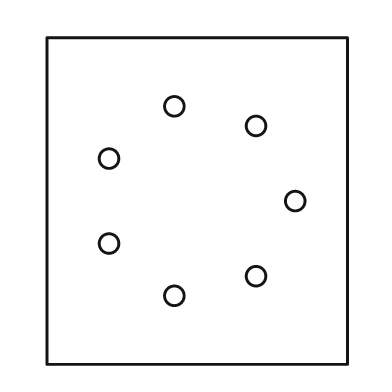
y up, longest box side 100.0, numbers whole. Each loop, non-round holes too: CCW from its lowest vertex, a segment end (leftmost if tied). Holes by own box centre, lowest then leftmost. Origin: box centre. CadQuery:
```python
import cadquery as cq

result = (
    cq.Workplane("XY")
    .moveTo(-46.0, -50.0)
    .lineTo(46.0, -50.0)
    .lineTo(46.0, 50.0)
    .lineTo(-46.0, 50.0)
    .close()
    .moveTo(-7.0, -29.0)
    .circle(3.0)
    .moveTo(18.0, -23.0)
    .circle(3.0)
    .moveTo(-27.0, -13.0)
    .circle(3.0)
    .moveTo(30.0, 0.0)
    .circle(3.0)
    .moveTo(-27.0, 13.0)
    .circle(3.0)
    .moveTo(18.0, 23.0)
    .circle(3.0)
    .moveTo(-7.0, 29.0)
    .circle(3.0)
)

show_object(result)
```